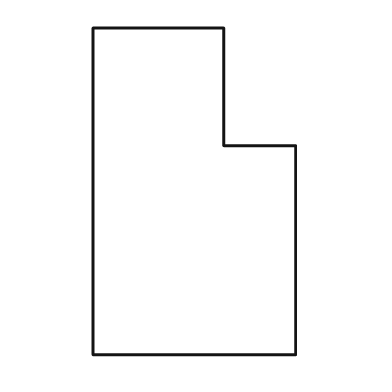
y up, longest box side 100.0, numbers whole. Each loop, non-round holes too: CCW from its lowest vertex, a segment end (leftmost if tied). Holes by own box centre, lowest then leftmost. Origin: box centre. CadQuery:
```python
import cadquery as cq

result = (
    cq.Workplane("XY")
    .moveTo(-31.0, -50.0)
    .lineTo(31.0, -50.0)
    .lineTo(31.0, 14.0)
    .lineTo(9.0, 14.0)
    .lineTo(9.0, 50.0)
    .lineTo(-31.0, 50.0)
    .close()
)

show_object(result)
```